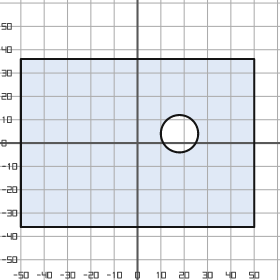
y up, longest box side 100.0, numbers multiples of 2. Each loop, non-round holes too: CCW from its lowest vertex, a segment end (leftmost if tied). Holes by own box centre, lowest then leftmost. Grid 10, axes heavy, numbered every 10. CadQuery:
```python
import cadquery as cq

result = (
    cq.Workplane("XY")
    .moveTo(-50.0, -36.0)
    .lineTo(50.0, -36.0)
    .lineTo(50.0, 36.0)
    .lineTo(-50.0, 36.0)
    .close()
    .moveTo(18.0, 4.0)
    .circle(8.0)
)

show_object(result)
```